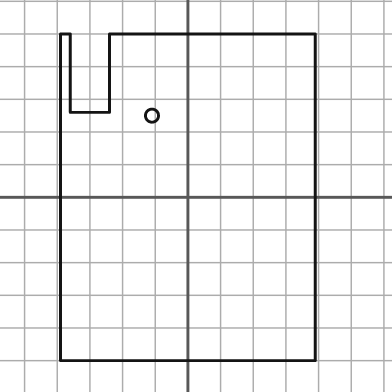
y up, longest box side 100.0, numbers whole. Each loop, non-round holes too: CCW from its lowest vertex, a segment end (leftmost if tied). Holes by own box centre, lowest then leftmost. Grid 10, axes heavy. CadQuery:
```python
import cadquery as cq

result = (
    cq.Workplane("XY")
    .moveTo(-39.0, -50.0)
    .lineTo(39.0, -50.0)
    .lineTo(39.0, 50.0)
    .lineTo(-24.0, 50.0)
    .lineTo(-24.0, 26.0)
    .lineTo(-36.0, 26.0)
    .lineTo(-36.0, 50.0)
    .lineTo(-39.0, 50.0)
    .close()
    .moveTo(-11.0, 25.0)
    .circle(2.0)
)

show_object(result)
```